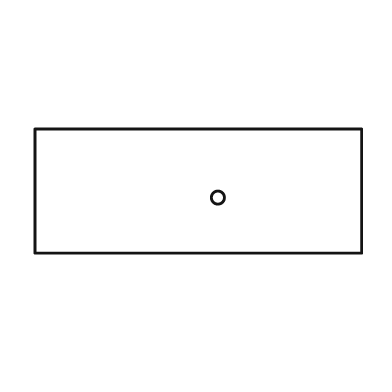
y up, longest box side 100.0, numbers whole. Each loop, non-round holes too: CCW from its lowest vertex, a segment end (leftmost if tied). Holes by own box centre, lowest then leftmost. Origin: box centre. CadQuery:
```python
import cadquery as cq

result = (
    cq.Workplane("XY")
    .moveTo(-50.0, -19.0)
    .lineTo(50.0, -19.0)
    .lineTo(50.0, 19.0)
    .lineTo(-50.0, 19.0)
    .close()
    .moveTo(6.0, -2.0)
    .circle(2.0)
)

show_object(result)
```